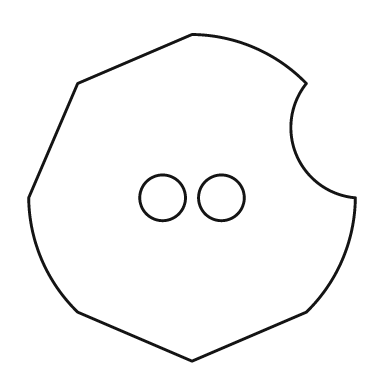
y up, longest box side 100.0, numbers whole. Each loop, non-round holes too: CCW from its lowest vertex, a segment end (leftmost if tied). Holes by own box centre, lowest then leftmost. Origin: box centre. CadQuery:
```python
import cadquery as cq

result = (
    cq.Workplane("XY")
    .moveTo(0.0, -50.0)
    .lineTo(35.0, -35.0)
    .threePointArc((46.0, -19.0), (50.0, 0.0))
    .threePointArc((32.0, 13.0), (35.0, 35.0))
    .threePointArc((19.0, 46.0), (0.0, 50.0))
    .lineTo(-35.0, 35.0)
    .lineTo(-50.0, 0.0)
    .threePointArc((-46.0, -19.0), (-35.0, -35.0))
    .close()
    .moveTo(-9.0, 0.0)
    .circle(7.0)
    .moveTo(9.0, 0.0)
    .circle(7.0)
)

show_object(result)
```